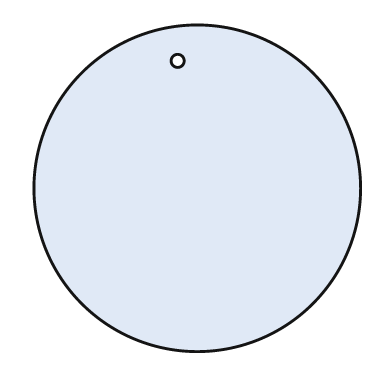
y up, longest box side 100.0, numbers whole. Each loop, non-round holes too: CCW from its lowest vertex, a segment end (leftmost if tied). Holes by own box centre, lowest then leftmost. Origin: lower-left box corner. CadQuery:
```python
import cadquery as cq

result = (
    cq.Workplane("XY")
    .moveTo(50.0, 50.0)
    .circle(50.0)
    .moveTo(44.0, 89.0)
    .circle(2.0)
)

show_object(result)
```